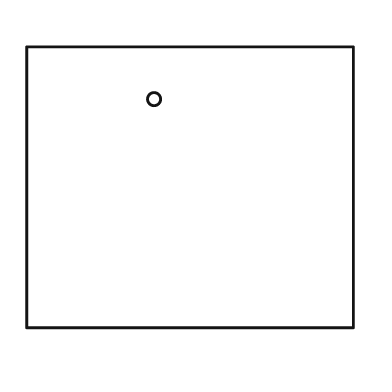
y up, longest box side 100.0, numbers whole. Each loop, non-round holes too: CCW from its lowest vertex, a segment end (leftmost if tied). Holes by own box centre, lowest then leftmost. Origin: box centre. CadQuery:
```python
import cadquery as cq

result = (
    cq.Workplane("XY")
    .moveTo(-50.0, -43.0)
    .lineTo(50.0, -43.0)
    .lineTo(50.0, 43.0)
    .lineTo(-50.0, 43.0)
    .close()
    .moveTo(-11.0, 27.0)
    .circle(2.0)
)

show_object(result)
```